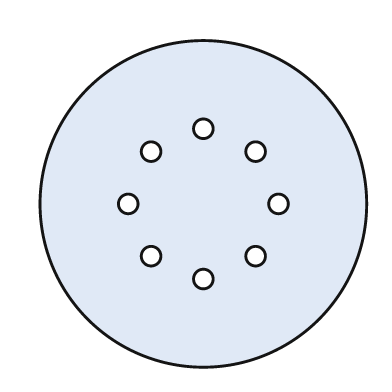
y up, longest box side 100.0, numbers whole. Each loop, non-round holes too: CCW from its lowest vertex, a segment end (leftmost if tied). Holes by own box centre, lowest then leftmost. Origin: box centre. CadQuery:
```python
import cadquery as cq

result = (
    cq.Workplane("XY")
    .moveTo(0.0, 0.0)
    .circle(50.0)
    .moveTo(0.0, -23.0)
    .circle(3.0)
    .moveTo(-16.0, -16.0)
    .circle(3.0)
    .moveTo(16.0, -16.0)
    .circle(3.0)
    .moveTo(-23.0, 0.0)
    .circle(3.0)
    .moveTo(23.0, 0.0)
    .circle(3.0)
    .moveTo(-16.0, 16.0)
    .circle(3.0)
    .moveTo(16.0, 16.0)
    .circle(3.0)
    .moveTo(0.0, 23.0)
    .circle(3.0)
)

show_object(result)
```